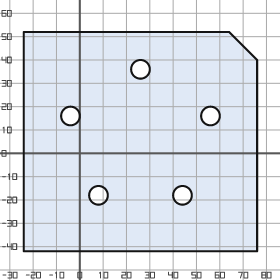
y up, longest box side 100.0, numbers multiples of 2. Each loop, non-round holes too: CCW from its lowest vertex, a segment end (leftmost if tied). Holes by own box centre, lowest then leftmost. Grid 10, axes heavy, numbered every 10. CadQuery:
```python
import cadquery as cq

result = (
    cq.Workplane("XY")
    .moveTo(-24.0, -42.0)
    .lineTo(76.0, -42.0)
    .lineTo(76.0, 40.0)
    .lineTo(64.0, 52.0)
    .lineTo(-24.0, 52.0)
    .close()
    .moveTo(8.0, -18.0)
    .circle(4.0)
    .moveTo(44.0, -18.0)
    .circle(4.0)
    .moveTo(-4.0, 16.0)
    .circle(4.0)
    .moveTo(56.0, 16.0)
    .circle(4.0)
    .moveTo(26.0, 36.0)
    .circle(4.0)
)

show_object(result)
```